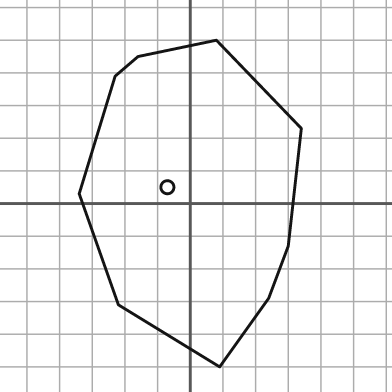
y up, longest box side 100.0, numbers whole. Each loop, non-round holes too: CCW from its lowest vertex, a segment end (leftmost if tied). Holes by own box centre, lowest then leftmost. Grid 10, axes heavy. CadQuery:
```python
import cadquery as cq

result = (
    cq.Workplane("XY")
    .moveTo(9.0, -50.0)
    .lineTo(24.0, -29.0)
    .lineTo(30.0, -13.0)
    .lineTo(34.0, 23.0)
    .lineTo(8.0, 50.0)
    .lineTo(-16.0, 45.0)
    .lineTo(-23.0, 39.0)
    .lineTo(-34.0, 3.0)
    .lineTo(-22.0, -31.0)
    .close()
    .moveTo(-7.0, 5.0)
    .circle(2.0)
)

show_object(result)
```